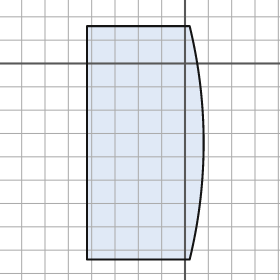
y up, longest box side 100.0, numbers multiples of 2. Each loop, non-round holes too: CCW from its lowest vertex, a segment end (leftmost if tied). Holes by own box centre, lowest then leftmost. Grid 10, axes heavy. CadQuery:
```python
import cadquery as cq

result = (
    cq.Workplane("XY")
    .moveTo(-42.0, -84.0)
    .lineTo(2.0, -84.0)
    .threePointArc((8.0, -34.0), (2.0, 16.0))
    .lineTo(-42.0, 16.0)
    .close()
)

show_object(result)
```